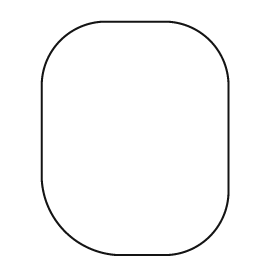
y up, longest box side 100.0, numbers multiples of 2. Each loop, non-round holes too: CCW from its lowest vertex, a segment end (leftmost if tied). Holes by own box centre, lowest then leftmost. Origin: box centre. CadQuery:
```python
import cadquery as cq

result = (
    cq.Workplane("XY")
    .moveTo(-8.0, -50.0)
    .lineTo(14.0, -50.0)
    .threePointArc((32.0, -42.0), (40.0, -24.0))
    .lineTo(40.0, 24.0)
    .threePointArc((32.0, 42.0), (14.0, 50.0))
    .lineTo(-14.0, 50.0)
    .threePointArc((-32.0, 42.0), (-40.0, 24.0))
    .lineTo(-40.0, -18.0)
    .threePointArc((-30.0, -40.0), (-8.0, -50.0))
    .close()
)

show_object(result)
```